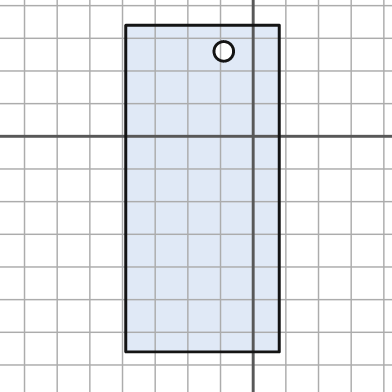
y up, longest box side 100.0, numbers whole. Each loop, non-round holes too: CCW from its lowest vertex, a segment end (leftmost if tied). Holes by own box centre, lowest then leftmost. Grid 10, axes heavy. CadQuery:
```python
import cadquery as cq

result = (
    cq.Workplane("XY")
    .moveTo(-39.0, -66.0)
    .lineTo(8.0, -66.0)
    .lineTo(8.0, 34.0)
    .lineTo(-39.0, 34.0)
    .close()
    .moveTo(-9.0, 26.0)
    .circle(3.0)
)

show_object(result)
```